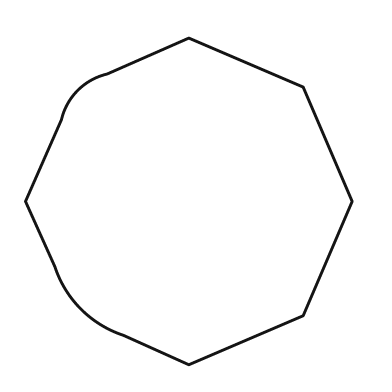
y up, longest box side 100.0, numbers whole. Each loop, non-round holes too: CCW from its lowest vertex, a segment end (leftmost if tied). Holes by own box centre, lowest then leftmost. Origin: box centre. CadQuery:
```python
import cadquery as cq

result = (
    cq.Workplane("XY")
    .moveTo(0.0, -50.0)
    .lineTo(35.0, -35.0)
    .lineTo(50.0, 0.0)
    .lineTo(35.0, 35.0)
    .lineTo(0.0, 50.0)
    .lineTo(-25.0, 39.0)
    .threePointArc((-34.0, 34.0), (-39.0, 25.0))
    .lineTo(-50.0, 0.0)
    .lineTo(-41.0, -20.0)
    .threePointArc((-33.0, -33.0), (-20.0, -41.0))
    .close()
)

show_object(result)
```